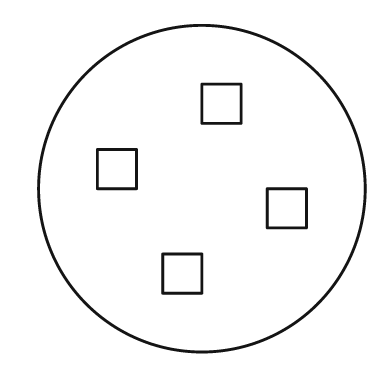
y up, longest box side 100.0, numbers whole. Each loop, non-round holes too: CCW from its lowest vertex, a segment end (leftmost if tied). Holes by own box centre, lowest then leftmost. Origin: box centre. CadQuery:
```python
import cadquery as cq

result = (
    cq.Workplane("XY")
    .moveTo(0.0, 0.0)
    .circle(50.0)
    .moveTo(-12.0, -32.0)
    .lineTo(0.0, -32.0)
    .lineTo(0.0, -20.0)
    .lineTo(-12.0, -20.0)
    .close()
    .moveTo(20.0, -12.0)
    .lineTo(32.0, -12.0)
    .lineTo(32.0, 0.0)
    .lineTo(20.0, 0.0)
    .close()
    .moveTo(-32.0, 0.0)
    .lineTo(-20.0, 0.0)
    .lineTo(-20.0, 12.0)
    .lineTo(-32.0, 12.0)
    .close()
    .moveTo(0.0, 20.0)
    .lineTo(12.0, 20.0)
    .lineTo(12.0, 32.0)
    .lineTo(0.0, 32.0)
    .close()
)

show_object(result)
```